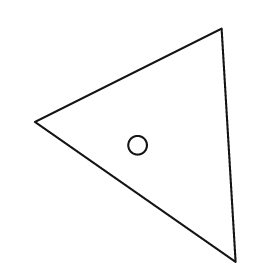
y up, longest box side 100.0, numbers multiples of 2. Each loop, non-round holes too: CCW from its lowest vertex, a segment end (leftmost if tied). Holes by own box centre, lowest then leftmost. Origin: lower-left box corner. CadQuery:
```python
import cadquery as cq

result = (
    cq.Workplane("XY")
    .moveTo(86.0, 0.0)
    .lineTo(80.0, 100.0)
    .lineTo(0.0, 60.0)
    .close()
    .moveTo(44.0, 50.0)
    .circle(4.0)
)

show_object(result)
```